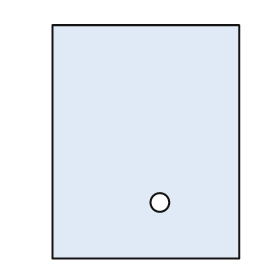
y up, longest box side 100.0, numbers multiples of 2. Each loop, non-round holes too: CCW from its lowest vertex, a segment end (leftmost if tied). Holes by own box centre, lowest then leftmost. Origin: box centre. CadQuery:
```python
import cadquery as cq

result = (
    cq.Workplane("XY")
    .moveTo(-40.0, -50.0)
    .lineTo(40.0, -50.0)
    .lineTo(40.0, 50.0)
    .lineTo(-40.0, 50.0)
    .close()
    .moveTo(6.0, -26.0)
    .circle(4.0)
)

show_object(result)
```